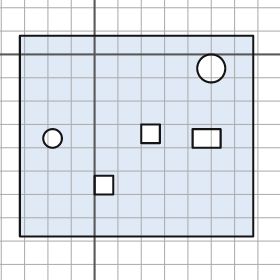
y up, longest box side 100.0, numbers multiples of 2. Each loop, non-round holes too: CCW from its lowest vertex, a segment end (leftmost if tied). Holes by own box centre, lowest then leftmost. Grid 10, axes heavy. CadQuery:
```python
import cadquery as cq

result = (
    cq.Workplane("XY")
    .moveTo(-32.0, -78.0)
    .lineTo(68.0, -78.0)
    .lineTo(68.0, 8.0)
    .lineTo(-32.0, 8.0)
    .close()
    .moveTo(0.0, -60.0)
    .lineTo(8.0, -60.0)
    .lineTo(8.0, -52.0)
    .lineTo(0.0, -52.0)
    .close()
    .moveTo(-18.0, -36.0)
    .circle(4.0)
    .moveTo(42.0, -40.0)
    .lineTo(54.0, -40.0)
    .lineTo(54.0, -32.0)
    .lineTo(42.0, -32.0)
    .close()
    .moveTo(20.0, -38.0)
    .lineTo(28.0, -38.0)
    .lineTo(28.0, -30.0)
    .lineTo(20.0, -30.0)
    .close()
    .moveTo(50.0, -6.0)
    .circle(6.0)
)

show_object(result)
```